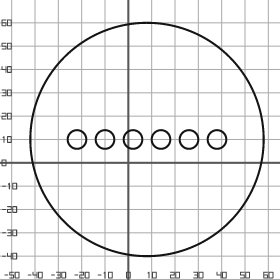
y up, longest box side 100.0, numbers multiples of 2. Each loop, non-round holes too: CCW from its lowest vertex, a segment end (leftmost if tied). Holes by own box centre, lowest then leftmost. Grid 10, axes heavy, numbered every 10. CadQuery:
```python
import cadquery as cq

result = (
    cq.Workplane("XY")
    .moveTo(8.0, 10.0)
    .circle(50.0)
    .moveTo(-22.0, 10.0)
    .circle(4.0)
    .moveTo(-10.0, 10.0)
    .circle(4.0)
    .moveTo(2.0, 10.0)
    .circle(4.0)
    .moveTo(14.0, 10.0)
    .circle(4.0)
    .moveTo(26.0, 10.0)
    .circle(4.0)
    .moveTo(38.0, 10.0)
    .circle(4.0)
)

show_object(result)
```